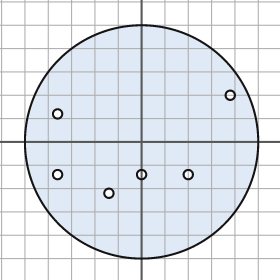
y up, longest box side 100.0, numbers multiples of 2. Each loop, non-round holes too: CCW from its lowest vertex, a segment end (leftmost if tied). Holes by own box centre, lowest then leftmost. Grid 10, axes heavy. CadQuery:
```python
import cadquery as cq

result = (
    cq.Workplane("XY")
    .moveTo(0.0, 0.0)
    .circle(50.0)
    .moveTo(-14.0, -22.0)
    .circle(2.0)
    .moveTo(-36.0, -14.0)
    .circle(2.0)
    .moveTo(0.0, -14.0)
    .circle(2.0)
    .moveTo(20.0, -14.0)
    .circle(2.0)
    .moveTo(-36.0, 12.0)
    .circle(2.0)
    .moveTo(38.0, 20.0)
    .circle(2.0)
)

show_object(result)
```